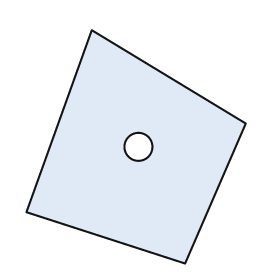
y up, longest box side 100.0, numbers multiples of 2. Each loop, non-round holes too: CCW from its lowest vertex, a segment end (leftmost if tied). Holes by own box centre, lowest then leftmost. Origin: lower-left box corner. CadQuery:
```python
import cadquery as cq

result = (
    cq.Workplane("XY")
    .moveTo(68.0, 0.0)
    .lineTo(94.0, 60.0)
    .lineTo(28.0, 100.0)
    .lineTo(0.0, 22.0)
    .close()
    .moveTo(48.0, 50.0)
    .circle(6.0)
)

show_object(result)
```